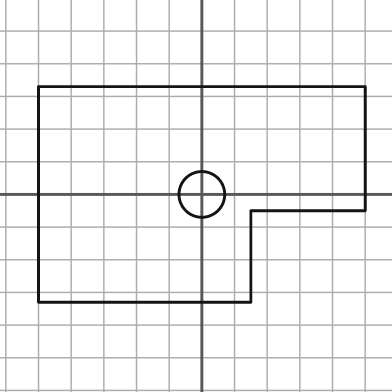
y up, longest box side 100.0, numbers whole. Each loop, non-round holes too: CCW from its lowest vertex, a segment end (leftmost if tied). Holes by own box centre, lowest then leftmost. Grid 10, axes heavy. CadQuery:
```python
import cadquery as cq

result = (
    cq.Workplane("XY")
    .moveTo(-50.0, -33.0)
    .lineTo(15.0, -33.0)
    .lineTo(15.0, -5.0)
    .lineTo(50.0, -5.0)
    .lineTo(50.0, 33.0)
    .lineTo(-50.0, 33.0)
    .close()
    .moveTo(0.0, 0.0)
    .circle(7.0)
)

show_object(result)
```